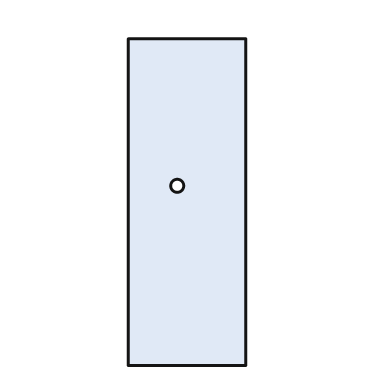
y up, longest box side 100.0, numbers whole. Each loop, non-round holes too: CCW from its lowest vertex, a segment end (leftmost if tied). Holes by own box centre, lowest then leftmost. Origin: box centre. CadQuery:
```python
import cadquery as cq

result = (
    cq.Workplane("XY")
    .moveTo(-18.0, -50.0)
    .lineTo(18.0, -50.0)
    .lineTo(18.0, 50.0)
    .lineTo(-18.0, 50.0)
    .close()
    .moveTo(-3.0, 5.0)
    .circle(2.0)
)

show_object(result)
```